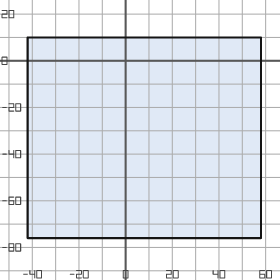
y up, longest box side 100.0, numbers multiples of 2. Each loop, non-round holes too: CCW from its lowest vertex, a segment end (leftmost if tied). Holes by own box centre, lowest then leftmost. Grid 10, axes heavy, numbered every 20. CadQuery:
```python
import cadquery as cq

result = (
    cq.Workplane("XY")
    .moveTo(-42.0, -76.0)
    .lineTo(58.0, -76.0)
    .lineTo(58.0, 10.0)
    .lineTo(-42.0, 10.0)
    .close()
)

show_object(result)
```